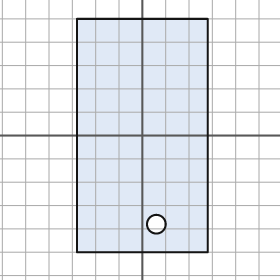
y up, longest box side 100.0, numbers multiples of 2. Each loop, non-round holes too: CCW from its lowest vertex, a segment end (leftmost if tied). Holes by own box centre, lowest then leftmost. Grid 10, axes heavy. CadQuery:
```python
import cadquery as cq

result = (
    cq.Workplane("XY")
    .moveTo(-28.0, -50.0)
    .lineTo(28.0, -50.0)
    .lineTo(28.0, 50.0)
    .lineTo(-28.0, 50.0)
    .close()
    .moveTo(6.0, -38.0)
    .circle(4.0)
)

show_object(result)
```